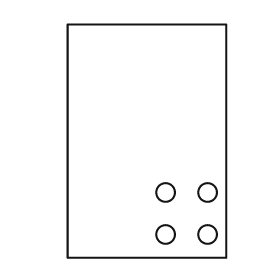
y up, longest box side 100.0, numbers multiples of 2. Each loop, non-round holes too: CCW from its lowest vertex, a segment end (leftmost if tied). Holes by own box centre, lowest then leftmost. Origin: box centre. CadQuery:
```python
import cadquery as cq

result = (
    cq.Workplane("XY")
    .moveTo(-34.0, -50.0)
    .lineTo(34.0, -50.0)
    .lineTo(34.0, 50.0)
    .lineTo(-34.0, 50.0)
    .close()
    .moveTo(8.0, -40.0)
    .circle(4.0)
    .moveTo(26.0, -40.0)
    .circle(4.0)
    .moveTo(8.0, -22.0)
    .circle(4.0)
    .moveTo(26.0, -22.0)
    .circle(4.0)
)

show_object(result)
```